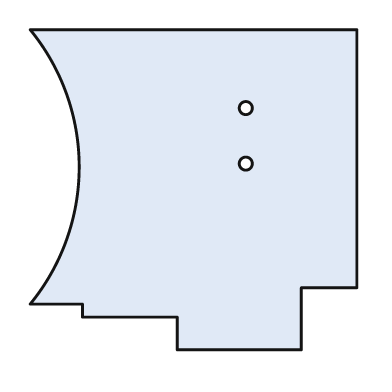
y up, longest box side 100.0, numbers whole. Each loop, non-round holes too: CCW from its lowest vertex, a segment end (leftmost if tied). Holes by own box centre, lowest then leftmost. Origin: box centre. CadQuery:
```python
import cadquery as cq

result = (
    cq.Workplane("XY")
    .moveTo(-5.0, -49.0)
    .lineTo(33.0, -49.0)
    .lineTo(33.0, -30.0)
    .lineTo(50.0, -30.0)
    .lineTo(50.0, 49.0)
    .lineTo(-50.0, 49.0)
    .threePointArc((-35.0, 7.0), (-50.0, -35.0))
    .lineTo(-34.0, -35.0)
    .lineTo(-34.0, -39.0)
    .lineTo(-5.0, -39.0)
    .close()
    .moveTo(16.0, 8.0)
    .circle(2.0)
    .moveTo(16.0, 25.0)
    .circle(2.0)
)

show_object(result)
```